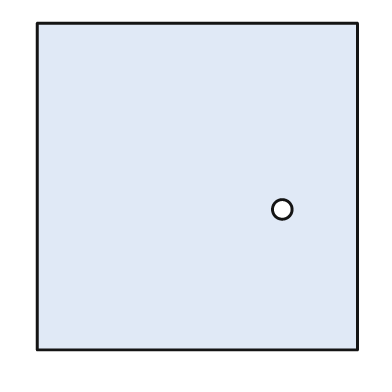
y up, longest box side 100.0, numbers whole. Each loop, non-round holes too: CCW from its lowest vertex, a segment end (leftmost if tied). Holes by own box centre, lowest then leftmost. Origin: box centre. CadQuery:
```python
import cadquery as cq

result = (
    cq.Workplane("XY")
    .moveTo(-49.0, -50.0)
    .lineTo(49.0, -50.0)
    .lineTo(49.0, 50.0)
    .lineTo(-49.0, 50.0)
    .close()
    .moveTo(26.0, -7.0)
    .circle(3.0)
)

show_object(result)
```